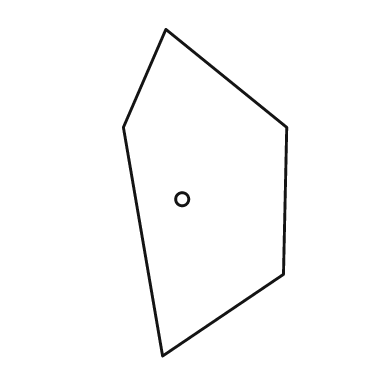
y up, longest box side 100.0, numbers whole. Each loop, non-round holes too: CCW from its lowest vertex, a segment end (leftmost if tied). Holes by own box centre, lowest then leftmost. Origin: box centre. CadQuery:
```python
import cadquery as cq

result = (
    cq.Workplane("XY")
    .moveTo(-13.0, -50.0)
    .lineTo(24.0, -25.0)
    .lineTo(25.0, 20.0)
    .lineTo(-12.0, 50.0)
    .lineTo(-25.0, 20.0)
    .close()
    .moveTo(-7.0, -2.0)
    .circle(2.0)
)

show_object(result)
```